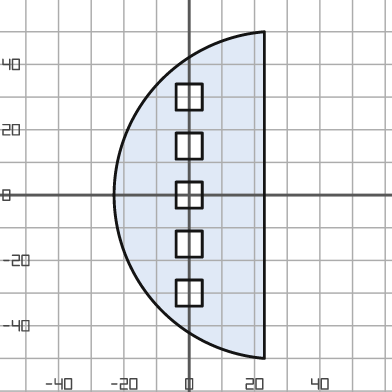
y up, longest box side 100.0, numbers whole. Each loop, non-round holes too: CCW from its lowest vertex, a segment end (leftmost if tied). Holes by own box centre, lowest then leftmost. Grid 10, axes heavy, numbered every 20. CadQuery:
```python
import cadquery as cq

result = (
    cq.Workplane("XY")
    .moveTo(23.0, -50.0)
    .lineTo(23.0, 50.0)
    .threePointArc((-23.0, 0.0), (23.0, -50.0))
    .close()
    .moveTo(-4.0, -34.0)
    .lineTo(4.0, -34.0)
    .lineTo(4.0, -26.0)
    .lineTo(-4.0, -26.0)
    .close()
    .moveTo(-4.0, -19.0)
    .lineTo(4.0, -19.0)
    .lineTo(4.0, -11.0)
    .lineTo(-4.0, -11.0)
    .close()
    .moveTo(-4.0, -4.0)
    .lineTo(4.0, -4.0)
    .lineTo(4.0, 4.0)
    .lineTo(-4.0, 4.0)
    .close()
    .moveTo(-4.0, 11.0)
    .lineTo(4.0, 11.0)
    .lineTo(4.0, 19.0)
    .lineTo(-4.0, 19.0)
    .close()
    .moveTo(-4.0, 26.0)
    .lineTo(4.0, 26.0)
    .lineTo(4.0, 34.0)
    .lineTo(-4.0, 34.0)
    .close()
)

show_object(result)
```